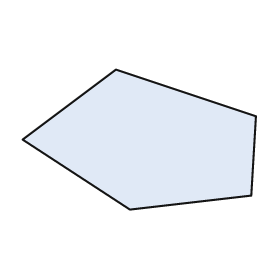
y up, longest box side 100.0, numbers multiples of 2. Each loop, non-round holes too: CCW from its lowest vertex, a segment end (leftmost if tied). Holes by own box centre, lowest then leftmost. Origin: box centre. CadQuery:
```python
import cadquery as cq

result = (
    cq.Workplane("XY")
    .moveTo(-4.0, -30.0)
    .lineTo(48.0, -24.0)
    .lineTo(50.0, 10.0)
    .lineTo(-10.0, 30.0)
    .lineTo(-50.0, 0.0)
    .close()
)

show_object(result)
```